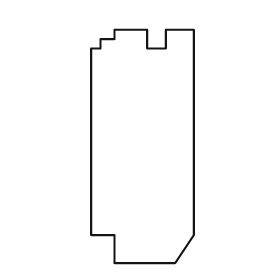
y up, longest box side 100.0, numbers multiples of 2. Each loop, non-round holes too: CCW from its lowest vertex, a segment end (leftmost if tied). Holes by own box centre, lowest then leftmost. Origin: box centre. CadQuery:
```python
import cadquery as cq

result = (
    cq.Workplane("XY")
    .moveTo(-12.0, -50.0)
    .lineTo(14.0, -50.0)
    .lineTo(22.0, -38.0)
    .lineTo(22.0, 50.0)
    .lineTo(10.0, 50.0)
    .lineTo(10.0, 42.0)
    .lineTo(2.0, 42.0)
    .lineTo(2.0, 50.0)
    .lineTo(-12.0, 50.0)
    .lineTo(-12.0, 46.0)
    .lineTo(-18.0, 46.0)
    .lineTo(-18.0, 42.0)
    .lineTo(-22.0, 42.0)
    .lineTo(-22.0, -38.0)
    .lineTo(-12.0, -38.0)
    .close()
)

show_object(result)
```